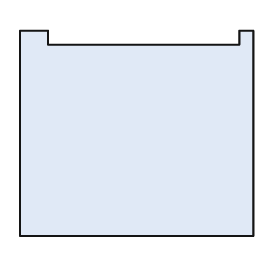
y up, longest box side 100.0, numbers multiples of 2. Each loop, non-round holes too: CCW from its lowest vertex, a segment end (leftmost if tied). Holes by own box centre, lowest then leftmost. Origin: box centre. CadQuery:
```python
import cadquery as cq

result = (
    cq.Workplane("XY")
    .moveTo(-50.0, -44.0)
    .lineTo(50.0, -44.0)
    .lineTo(50.0, 44.0)
    .lineTo(44.0, 44.0)
    .lineTo(44.0, 38.0)
    .lineTo(-38.0, 38.0)
    .lineTo(-38.0, 44.0)
    .lineTo(-50.0, 44.0)
    .close()
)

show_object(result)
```